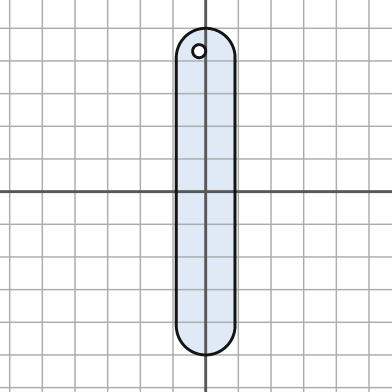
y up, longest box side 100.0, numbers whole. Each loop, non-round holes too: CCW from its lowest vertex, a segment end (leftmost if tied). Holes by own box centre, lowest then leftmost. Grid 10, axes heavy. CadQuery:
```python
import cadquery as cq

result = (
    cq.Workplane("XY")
    .moveTo(-9.0, -41.0)
    .threePointArc((0.0, -50.0), (9.0, -41.0))
    .lineTo(9.0, 41.0)
    .threePointArc((0.0, 50.0), (-9.0, 41.0))
    .close()
    .moveTo(-2.0, 43.0)
    .circle(2.0)
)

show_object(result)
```